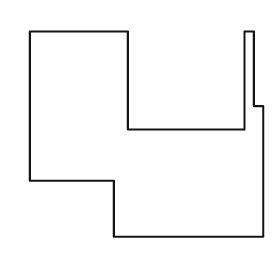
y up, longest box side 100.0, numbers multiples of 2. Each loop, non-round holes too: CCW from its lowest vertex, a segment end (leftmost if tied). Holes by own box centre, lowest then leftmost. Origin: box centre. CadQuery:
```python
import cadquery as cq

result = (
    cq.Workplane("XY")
    .moveTo(-14.0, -44.0)
    .lineTo(50.0, -44.0)
    .lineTo(50.0, 12.0)
    .lineTo(46.0, 12.0)
    .lineTo(46.0, 44.0)
    .lineTo(42.0, 44.0)
    .lineTo(42.0, 2.0)
    .lineTo(-8.0, 2.0)
    .lineTo(-8.0, 44.0)
    .lineTo(-50.0, 44.0)
    .lineTo(-50.0, -20.0)
    .lineTo(-14.0, -20.0)
    .close()
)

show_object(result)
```